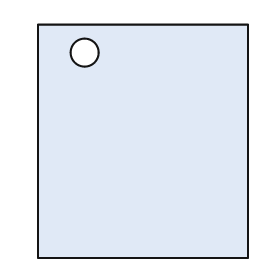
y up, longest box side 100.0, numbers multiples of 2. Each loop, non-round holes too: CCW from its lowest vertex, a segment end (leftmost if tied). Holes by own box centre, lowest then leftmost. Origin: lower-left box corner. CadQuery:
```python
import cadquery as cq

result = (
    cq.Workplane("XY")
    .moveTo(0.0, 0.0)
    .lineTo(90.0, 0.0)
    .lineTo(90.0, 100.0)
    .lineTo(0.0, 100.0)
    .close()
    .moveTo(20.0, 88.0)
    .circle(6.0)
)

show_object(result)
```